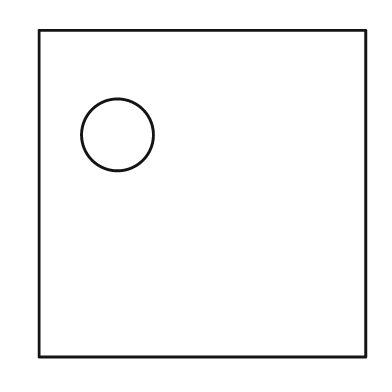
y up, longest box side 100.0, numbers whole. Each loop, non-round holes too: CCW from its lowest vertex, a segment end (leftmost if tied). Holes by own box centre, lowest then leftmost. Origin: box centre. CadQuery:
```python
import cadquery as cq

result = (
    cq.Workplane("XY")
    .moveTo(-50.0, -50.0)
    .lineTo(50.0, -50.0)
    .lineTo(50.0, 50.0)
    .lineTo(-50.0, 50.0)
    .close()
    .moveTo(-26.0, 18.0)
    .circle(11.0)
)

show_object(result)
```